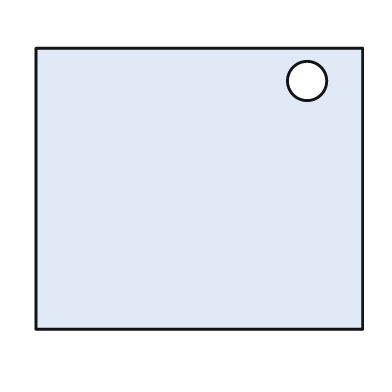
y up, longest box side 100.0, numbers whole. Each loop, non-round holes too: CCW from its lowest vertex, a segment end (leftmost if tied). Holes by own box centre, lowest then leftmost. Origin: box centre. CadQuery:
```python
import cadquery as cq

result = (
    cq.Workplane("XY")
    .moveTo(-50.0, -43.0)
    .lineTo(50.0, -43.0)
    .lineTo(50.0, 43.0)
    .lineTo(-50.0, 43.0)
    .close()
    .moveTo(33.0, 33.0)
    .circle(6.0)
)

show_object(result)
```